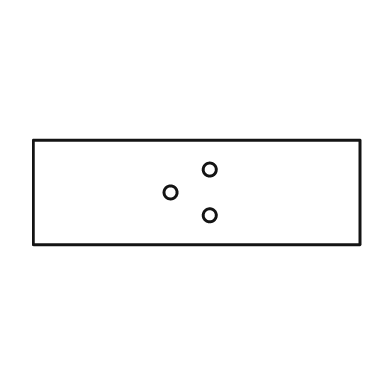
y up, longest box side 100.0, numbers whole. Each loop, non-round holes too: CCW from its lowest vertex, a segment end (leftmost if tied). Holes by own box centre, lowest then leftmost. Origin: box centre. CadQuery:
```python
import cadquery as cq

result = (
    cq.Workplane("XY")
    .moveTo(-50.0, -16.0)
    .lineTo(50.0, -16.0)
    .lineTo(50.0, 16.0)
    .lineTo(-50.0, 16.0)
    .close()
    .moveTo(4.0, -7.0)
    .circle(2.0)
    .moveTo(-8.0, 0.0)
    .circle(2.0)
    .moveTo(4.0, 7.0)
    .circle(2.0)
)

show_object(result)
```